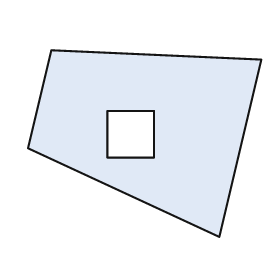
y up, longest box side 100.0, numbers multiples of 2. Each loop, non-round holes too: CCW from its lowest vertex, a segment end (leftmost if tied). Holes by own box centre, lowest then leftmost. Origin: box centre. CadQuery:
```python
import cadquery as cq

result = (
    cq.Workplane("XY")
    .moveTo(32.0, -40.0)
    .lineTo(50.0, 36.0)
    .lineTo(-40.0, 40.0)
    .lineTo(-50.0, -2.0)
    .close()
    .moveTo(-16.0, -6.0)
    .lineTo(4.0, -6.0)
    .lineTo(4.0, 14.0)
    .lineTo(-16.0, 14.0)
    .close()
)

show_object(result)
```